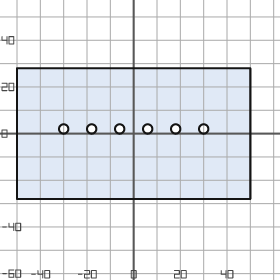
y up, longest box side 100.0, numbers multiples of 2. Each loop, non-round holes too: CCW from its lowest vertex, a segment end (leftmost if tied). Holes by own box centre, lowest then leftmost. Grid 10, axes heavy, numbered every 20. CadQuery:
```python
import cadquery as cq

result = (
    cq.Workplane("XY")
    .moveTo(-50.0, -28.0)
    .lineTo(50.0, -28.0)
    .lineTo(50.0, 28.0)
    .lineTo(-50.0, 28.0)
    .close()
    .moveTo(-30.0, 2.0)
    .circle(2.0)
    .moveTo(-18.0, 2.0)
    .circle(2.0)
    .moveTo(-6.0, 2.0)
    .circle(2.0)
    .moveTo(6.0, 2.0)
    .circle(2.0)
    .moveTo(18.0, 2.0)
    .circle(2.0)
    .moveTo(30.0, 2.0)
    .circle(2.0)
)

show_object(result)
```